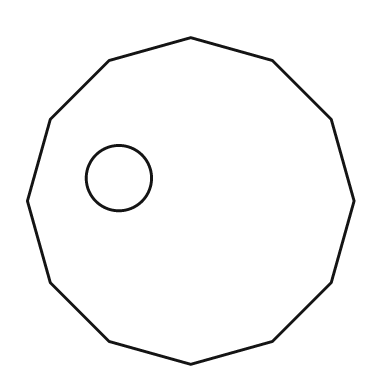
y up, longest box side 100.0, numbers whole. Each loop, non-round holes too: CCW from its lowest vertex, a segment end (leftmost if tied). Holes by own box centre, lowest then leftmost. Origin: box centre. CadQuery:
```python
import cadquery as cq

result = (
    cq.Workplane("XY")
    .moveTo(0.0, -50.0)
    .lineTo(25.0, -43.0)
    .lineTo(43.0, -25.0)
    .lineTo(50.0, 0.0)
    .lineTo(43.0, 25.0)
    .lineTo(25.0, 43.0)
    .lineTo(0.0, 50.0)
    .lineTo(-25.0, 43.0)
    .lineTo(-43.0, 25.0)
    .lineTo(-50.0, 0.0)
    .lineTo(-43.0, -25.0)
    .lineTo(-25.0, -43.0)
    .close()
    .moveTo(-22.0, 7.0)
    .circle(10.0)
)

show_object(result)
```